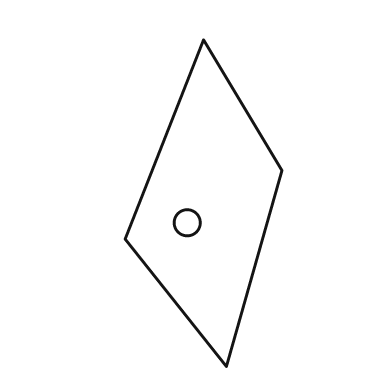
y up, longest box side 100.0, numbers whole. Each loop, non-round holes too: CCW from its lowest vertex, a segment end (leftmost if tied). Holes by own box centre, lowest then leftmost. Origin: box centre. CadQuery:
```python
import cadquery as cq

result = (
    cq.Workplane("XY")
    .moveTo(7.0, -50.0)
    .lineTo(24.0, 10.0)
    .lineTo(0.0, 50.0)
    .lineTo(-24.0, -11.0)
    .close()
    .moveTo(-5.0, -6.0)
    .circle(4.0)
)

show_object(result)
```